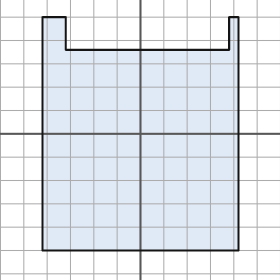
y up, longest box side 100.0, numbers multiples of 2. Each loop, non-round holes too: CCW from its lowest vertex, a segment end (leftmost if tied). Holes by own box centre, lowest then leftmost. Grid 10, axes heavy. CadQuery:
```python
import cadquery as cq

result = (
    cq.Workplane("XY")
    .moveTo(-42.0, -50.0)
    .lineTo(42.0, -50.0)
    .lineTo(42.0, 50.0)
    .lineTo(38.0, 50.0)
    .lineTo(38.0, 36.0)
    .lineTo(-32.0, 36.0)
    .lineTo(-32.0, 50.0)
    .lineTo(-42.0, 50.0)
    .close()
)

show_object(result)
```